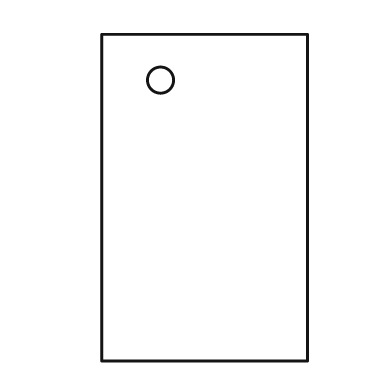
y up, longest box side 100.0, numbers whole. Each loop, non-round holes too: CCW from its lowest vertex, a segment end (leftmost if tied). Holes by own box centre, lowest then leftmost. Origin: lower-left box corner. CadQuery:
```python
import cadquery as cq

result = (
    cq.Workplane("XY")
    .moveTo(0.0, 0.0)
    .lineTo(63.0, 0.0)
    .lineTo(63.0, 100.0)
    .lineTo(0.0, 100.0)
    .close()
    .moveTo(18.0, 86.0)
    .circle(4.0)
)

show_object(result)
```